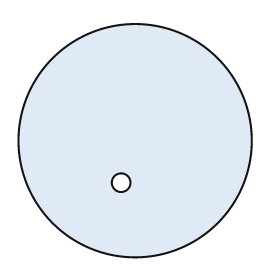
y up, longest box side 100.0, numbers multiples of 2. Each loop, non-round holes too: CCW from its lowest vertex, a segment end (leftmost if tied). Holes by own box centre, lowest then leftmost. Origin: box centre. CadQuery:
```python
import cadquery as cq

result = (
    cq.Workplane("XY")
    .moveTo(0.0, 0.0)
    .circle(50.0)
    .moveTo(-6.0, -18.0)
    .circle(4.0)
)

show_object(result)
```